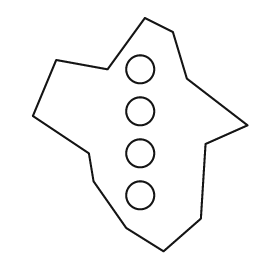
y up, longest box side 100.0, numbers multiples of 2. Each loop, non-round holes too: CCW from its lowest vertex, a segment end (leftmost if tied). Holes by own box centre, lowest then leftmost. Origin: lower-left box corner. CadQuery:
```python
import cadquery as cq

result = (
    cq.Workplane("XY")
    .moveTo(56.0, 0.0)
    .lineTo(72.0, 14.0)
    .lineTo(74.0, 46.0)
    .lineTo(92.0, 54.0)
    .lineTo(66.0, 74.0)
    .lineTo(60.0, 94.0)
    .lineTo(48.0, 100.0)
    .lineTo(32.0, 78.0)
    .lineTo(10.0, 82.0)
    .lineTo(0.0, 58.0)
    .lineTo(24.0, 42.0)
    .lineTo(26.0, 30.0)
    .lineTo(40.0, 10.0)
    .close()
    .moveTo(46.0, 24.0)
    .circle(6.0)
    .moveTo(46.0, 42.0)
    .circle(6.0)
    .moveTo(46.0, 60.0)
    .circle(6.0)
    .moveTo(46.0, 78.0)
    .circle(6.0)
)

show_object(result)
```